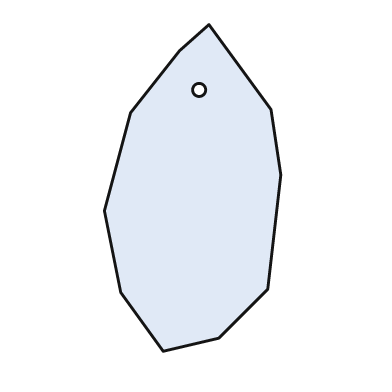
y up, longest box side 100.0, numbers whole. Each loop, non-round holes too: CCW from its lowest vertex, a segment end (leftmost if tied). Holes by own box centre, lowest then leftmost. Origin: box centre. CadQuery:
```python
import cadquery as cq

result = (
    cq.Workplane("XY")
    .moveTo(-9.0, -50.0)
    .lineTo(8.0, -46.0)
    .lineTo(23.0, -31.0)
    .lineTo(27.0, 4.0)
    .lineTo(24.0, 24.0)
    .lineTo(5.0, 50.0)
    .lineTo(-4.0, 42.0)
    .lineTo(-19.0, 23.0)
    .lineTo(-27.0, -7.0)
    .lineTo(-22.0, -32.0)
    .close()
    .moveTo(2.0, 30.0)
    .circle(2.0)
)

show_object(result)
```